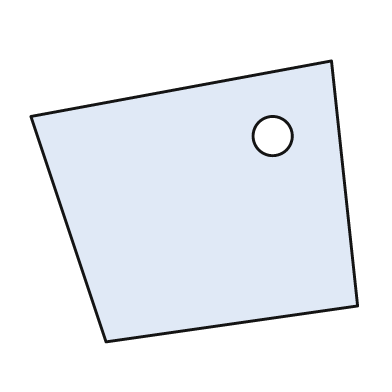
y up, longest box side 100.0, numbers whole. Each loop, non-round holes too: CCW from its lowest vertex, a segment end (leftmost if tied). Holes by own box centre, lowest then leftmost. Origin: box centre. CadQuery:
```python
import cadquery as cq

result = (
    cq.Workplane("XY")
    .moveTo(-27.0, -43.0)
    .lineTo(50.0, -32.0)
    .lineTo(42.0, 43.0)
    .lineTo(-50.0, 26.0)
    .close()
    .moveTo(24.0, 20.0)
    .circle(6.0)
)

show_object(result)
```